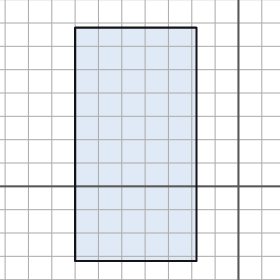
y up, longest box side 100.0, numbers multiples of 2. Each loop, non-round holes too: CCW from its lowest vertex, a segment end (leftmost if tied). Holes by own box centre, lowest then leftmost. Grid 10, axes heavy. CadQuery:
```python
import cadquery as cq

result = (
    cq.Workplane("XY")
    .moveTo(-70.0, -32.0)
    .lineTo(-18.0, -32.0)
    .lineTo(-18.0, 68.0)
    .lineTo(-70.0, 68.0)
    .close()
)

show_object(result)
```